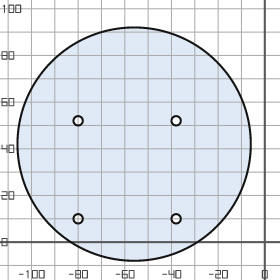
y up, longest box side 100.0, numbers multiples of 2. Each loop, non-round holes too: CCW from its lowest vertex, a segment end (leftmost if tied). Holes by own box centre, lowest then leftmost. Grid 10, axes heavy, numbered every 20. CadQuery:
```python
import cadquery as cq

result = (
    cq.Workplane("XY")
    .moveTo(-56.0, 42.0)
    .circle(50.0)
    .moveTo(-80.0, 10.0)
    .circle(2.0)
    .moveTo(-38.0, 10.0)
    .circle(2.0)
    .moveTo(-80.0, 52.0)
    .circle(2.0)
    .moveTo(-38.0, 52.0)
    .circle(2.0)
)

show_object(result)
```